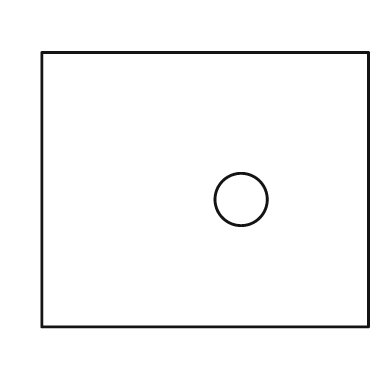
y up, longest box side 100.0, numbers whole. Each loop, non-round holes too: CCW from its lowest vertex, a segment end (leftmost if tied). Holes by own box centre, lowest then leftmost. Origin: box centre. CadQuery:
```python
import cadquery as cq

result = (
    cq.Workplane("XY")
    .moveTo(-50.0, -42.0)
    .lineTo(50.0, -42.0)
    .lineTo(50.0, 42.0)
    .lineTo(-50.0, 42.0)
    .close()
    .moveTo(11.0, -3.0)
    .circle(8.0)
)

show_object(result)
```